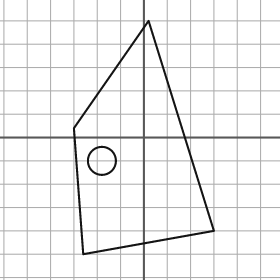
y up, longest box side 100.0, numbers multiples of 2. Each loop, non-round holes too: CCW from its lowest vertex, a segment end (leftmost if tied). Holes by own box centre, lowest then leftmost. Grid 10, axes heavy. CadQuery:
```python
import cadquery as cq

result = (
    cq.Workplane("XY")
    .moveTo(-26.0, -50.0)
    .lineTo(30.0, -40.0)
    .lineTo(2.0, 50.0)
    .lineTo(-30.0, 4.0)
    .close()
    .moveTo(-18.0, -10.0)
    .circle(6.0)
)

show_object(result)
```